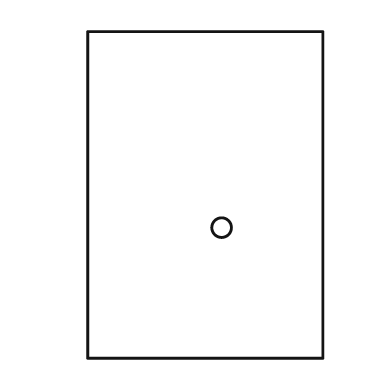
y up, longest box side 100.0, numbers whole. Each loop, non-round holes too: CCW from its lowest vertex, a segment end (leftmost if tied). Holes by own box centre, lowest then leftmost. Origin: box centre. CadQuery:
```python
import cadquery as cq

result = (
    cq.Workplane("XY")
    .moveTo(-36.0, -50.0)
    .lineTo(36.0, -50.0)
    .lineTo(36.0, 50.0)
    .lineTo(-36.0, 50.0)
    .close()
    .moveTo(5.0, -10.0)
    .circle(3.0)
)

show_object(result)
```